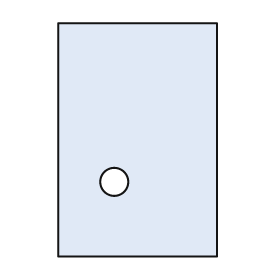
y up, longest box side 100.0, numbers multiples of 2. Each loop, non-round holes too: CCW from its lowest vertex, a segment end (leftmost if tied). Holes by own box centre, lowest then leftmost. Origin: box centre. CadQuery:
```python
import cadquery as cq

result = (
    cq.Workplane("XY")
    .moveTo(-34.0, -50.0)
    .lineTo(34.0, -50.0)
    .lineTo(34.0, 50.0)
    .lineTo(-34.0, 50.0)
    .close()
    .moveTo(-10.0, -18.0)
    .circle(6.0)
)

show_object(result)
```